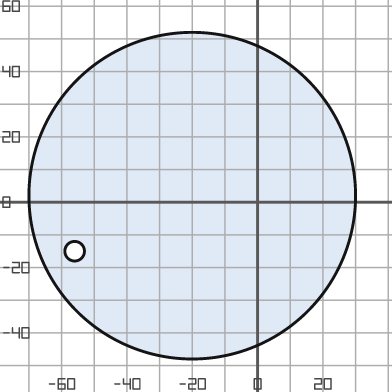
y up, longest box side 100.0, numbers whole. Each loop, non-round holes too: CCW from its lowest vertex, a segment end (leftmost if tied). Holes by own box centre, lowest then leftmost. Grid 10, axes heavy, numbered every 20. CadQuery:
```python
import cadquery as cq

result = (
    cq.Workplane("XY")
    .moveTo(-20.0, 2.0)
    .circle(50.0)
    .moveTo(-56.0, -15.0)
    .circle(3.0)
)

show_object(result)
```